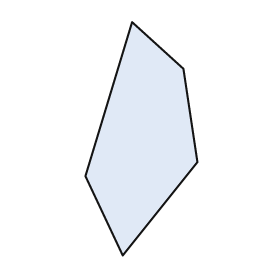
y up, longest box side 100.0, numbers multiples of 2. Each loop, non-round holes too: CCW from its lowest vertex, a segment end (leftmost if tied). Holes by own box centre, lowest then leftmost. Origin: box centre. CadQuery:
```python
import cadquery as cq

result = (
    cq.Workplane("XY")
    .moveTo(-8.0, -50.0)
    .lineTo(24.0, -10.0)
    .lineTo(18.0, 30.0)
    .lineTo(-4.0, 50.0)
    .lineTo(-24.0, -16.0)
    .close()
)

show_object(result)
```